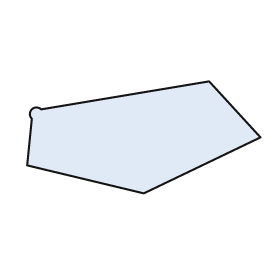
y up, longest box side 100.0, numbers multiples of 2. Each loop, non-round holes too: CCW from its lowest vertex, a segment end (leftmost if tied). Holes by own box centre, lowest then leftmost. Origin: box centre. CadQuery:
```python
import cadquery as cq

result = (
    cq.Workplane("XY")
    .moveTo(0.0, -24.0)
    .lineTo(50.0, 0.0)
    .lineTo(28.0, 24.0)
    .lineTo(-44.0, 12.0)
    .threePointArc((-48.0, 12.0), (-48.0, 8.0))
    .lineTo(-50.0, -12.0)
    .close()
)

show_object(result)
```